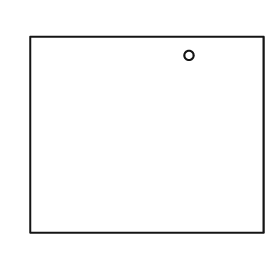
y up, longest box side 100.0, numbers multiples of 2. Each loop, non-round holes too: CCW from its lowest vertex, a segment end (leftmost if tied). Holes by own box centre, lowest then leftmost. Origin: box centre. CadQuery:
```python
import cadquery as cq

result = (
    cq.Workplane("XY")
    .moveTo(-50.0, -42.0)
    .lineTo(50.0, -42.0)
    .lineTo(50.0, 42.0)
    .lineTo(-50.0, 42.0)
    .close()
    .moveTo(18.0, 34.0)
    .circle(2.0)
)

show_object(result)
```